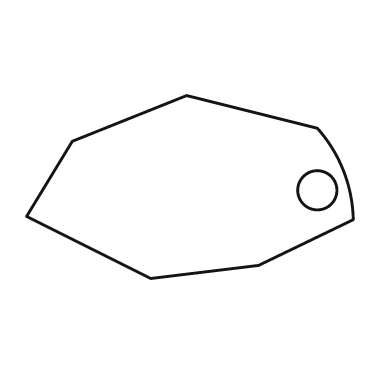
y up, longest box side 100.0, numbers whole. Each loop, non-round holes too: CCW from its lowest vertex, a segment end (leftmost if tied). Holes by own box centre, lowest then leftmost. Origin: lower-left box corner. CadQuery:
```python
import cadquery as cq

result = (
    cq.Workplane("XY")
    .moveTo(38.0, 0.0)
    .lineTo(71.0, 4.0)
    .lineTo(100.0, 18.0)
    .threePointArc((97.0, 33.0), (89.0, 46.0))
    .lineTo(49.0, 56.0)
    .lineTo(14.0, 42.0)
    .lineTo(0.0, 19.0)
    .close()
    .moveTo(89.0, 27.0)
    .circle(6.0)
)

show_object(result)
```